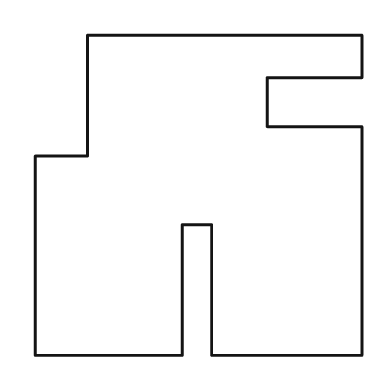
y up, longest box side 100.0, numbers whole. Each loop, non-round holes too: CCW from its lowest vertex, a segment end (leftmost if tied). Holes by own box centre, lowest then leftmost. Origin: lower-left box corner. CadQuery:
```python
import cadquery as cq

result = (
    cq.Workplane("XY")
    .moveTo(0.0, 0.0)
    .lineTo(45.0, 0.0)
    .lineTo(45.0, 40.0)
    .lineTo(54.0, 40.0)
    .lineTo(54.0, 0.0)
    .lineTo(100.0, 0.0)
    .lineTo(100.0, 70.0)
    .lineTo(71.0, 70.0)
    .lineTo(71.0, 85.0)
    .lineTo(100.0, 85.0)
    .lineTo(100.0, 98.0)
    .lineTo(16.0, 98.0)
    .lineTo(16.0, 61.0)
    .lineTo(0.0, 61.0)
    .close()
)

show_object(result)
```